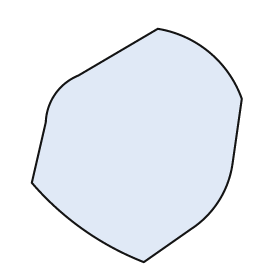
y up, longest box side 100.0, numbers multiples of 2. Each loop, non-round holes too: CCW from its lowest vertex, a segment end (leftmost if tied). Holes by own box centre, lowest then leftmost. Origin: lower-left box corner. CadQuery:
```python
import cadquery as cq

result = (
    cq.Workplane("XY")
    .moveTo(48.0, 0.0)
    .lineTo(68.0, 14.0)
    .threePointArc((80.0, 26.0), (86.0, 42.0))
    .lineTo(90.0, 70.0)
    .threePointArc((76.0, 90.0), (54.0, 100.0))
    .lineTo(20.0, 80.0)
    .threePointArc((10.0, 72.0), (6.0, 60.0))
    .lineTo(0.0, 34.0)
    .threePointArc((22.0, 14.0), (48.0, 0.0))
    .close()
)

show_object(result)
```